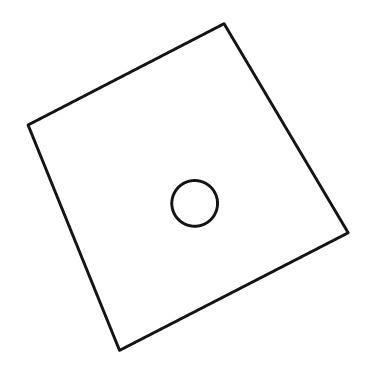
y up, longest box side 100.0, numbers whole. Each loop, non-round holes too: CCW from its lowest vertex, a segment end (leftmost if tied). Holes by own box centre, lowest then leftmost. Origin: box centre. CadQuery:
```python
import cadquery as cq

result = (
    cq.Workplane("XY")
    .moveTo(-21.0, -50.0)
    .lineTo(49.0, -14.0)
    .lineTo(11.0, 50.0)
    .lineTo(-49.0, 19.0)
    .close()
    .moveTo(2.0, -5.0)
    .circle(7.0)
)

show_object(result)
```